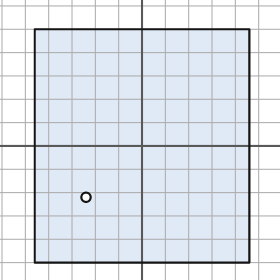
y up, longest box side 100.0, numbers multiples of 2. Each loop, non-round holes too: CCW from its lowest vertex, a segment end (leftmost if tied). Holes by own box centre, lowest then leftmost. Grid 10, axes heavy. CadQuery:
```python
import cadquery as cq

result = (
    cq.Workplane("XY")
    .moveTo(-46.0, -50.0)
    .lineTo(46.0, -50.0)
    .lineTo(46.0, 50.0)
    .lineTo(-46.0, 50.0)
    .close()
    .moveTo(-24.0, -22.0)
    .circle(2.0)
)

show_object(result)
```